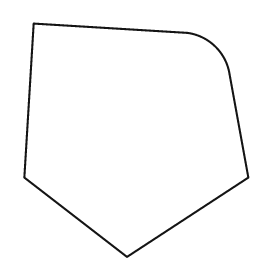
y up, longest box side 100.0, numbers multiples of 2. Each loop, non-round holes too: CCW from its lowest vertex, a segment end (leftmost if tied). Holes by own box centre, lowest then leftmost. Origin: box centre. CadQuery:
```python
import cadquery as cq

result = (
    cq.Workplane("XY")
    .moveTo(-4.0, -50.0)
    .lineTo(48.0, -16.0)
    .lineTo(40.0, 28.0)
    .threePointArc((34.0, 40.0), (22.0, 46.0))
    .lineTo(-44.0, 50.0)
    .lineTo(-48.0, -16.0)
    .close()
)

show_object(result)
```